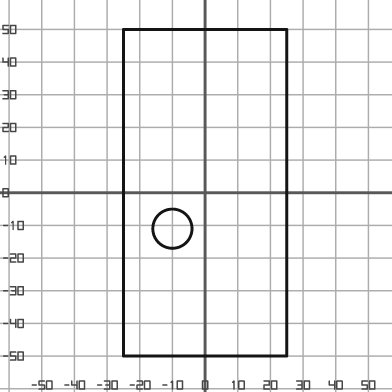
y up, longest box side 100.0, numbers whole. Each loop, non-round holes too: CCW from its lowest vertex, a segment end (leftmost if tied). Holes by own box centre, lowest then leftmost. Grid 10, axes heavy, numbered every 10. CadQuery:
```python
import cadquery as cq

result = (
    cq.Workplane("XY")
    .moveTo(-25.0, -50.0)
    .lineTo(25.0, -50.0)
    .lineTo(25.0, 50.0)
    .lineTo(-25.0, 50.0)
    .close()
    .moveTo(-10.0, -11.0)
    .circle(6.0)
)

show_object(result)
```